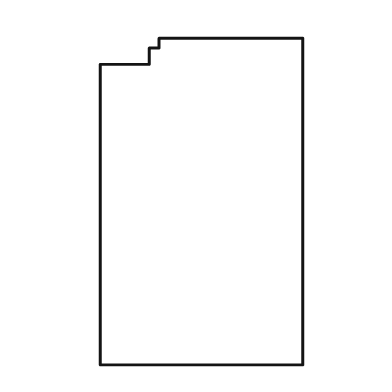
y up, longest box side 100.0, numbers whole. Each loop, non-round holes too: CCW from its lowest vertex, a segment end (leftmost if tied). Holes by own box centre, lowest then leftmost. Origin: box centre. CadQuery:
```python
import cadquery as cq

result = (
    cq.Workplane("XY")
    .moveTo(-31.0, -50.0)
    .lineTo(31.0, -50.0)
    .lineTo(31.0, 50.0)
    .lineTo(-13.0, 50.0)
    .lineTo(-13.0, 47.0)
    .lineTo(-16.0, 47.0)
    .lineTo(-16.0, 42.0)
    .lineTo(-31.0, 42.0)
    .close()
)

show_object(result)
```